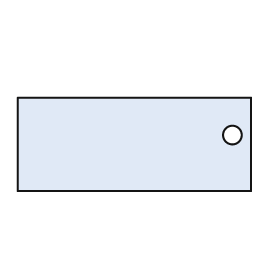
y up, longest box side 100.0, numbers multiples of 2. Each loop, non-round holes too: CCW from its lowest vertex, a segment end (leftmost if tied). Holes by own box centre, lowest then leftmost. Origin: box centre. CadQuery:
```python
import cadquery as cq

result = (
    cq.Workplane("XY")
    .moveTo(-50.0, -20.0)
    .lineTo(50.0, -20.0)
    .lineTo(50.0, 20.0)
    .lineTo(-50.0, 20.0)
    .close()
    .moveTo(42.0, 4.0)
    .circle(4.0)
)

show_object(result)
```